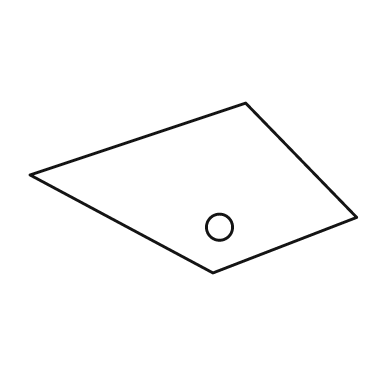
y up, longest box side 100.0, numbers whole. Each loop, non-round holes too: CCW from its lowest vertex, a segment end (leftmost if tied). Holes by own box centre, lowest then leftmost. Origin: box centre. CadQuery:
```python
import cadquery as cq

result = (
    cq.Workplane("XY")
    .moveTo(6.0, -26.0)
    .lineTo(50.0, -9.0)
    .lineTo(16.0, 26.0)
    .lineTo(-50.0, 4.0)
    .close()
    .moveTo(8.0, -12.0)
    .circle(4.0)
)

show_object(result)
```